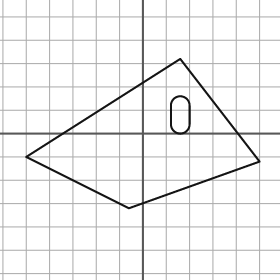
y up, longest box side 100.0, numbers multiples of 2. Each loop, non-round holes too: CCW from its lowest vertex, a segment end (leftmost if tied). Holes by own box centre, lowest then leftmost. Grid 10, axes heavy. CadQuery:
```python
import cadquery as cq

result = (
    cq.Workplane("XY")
    .moveTo(-6.0, -32.0)
    .lineTo(50.0, -12.0)
    .lineTo(16.0, 32.0)
    .lineTo(-50.0, -10.0)
    .close()
    .moveTo(12.0, 4.0)
    .threePointArc((16.0, 0.0), (20.0, 4.0))
    .lineTo(20.0, 12.0)
    .threePointArc((16.0, 16.0), (12.0, 12.0))
    .close()
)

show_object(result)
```